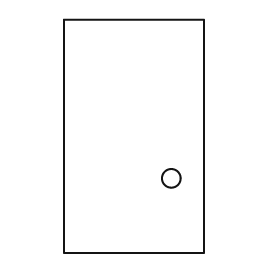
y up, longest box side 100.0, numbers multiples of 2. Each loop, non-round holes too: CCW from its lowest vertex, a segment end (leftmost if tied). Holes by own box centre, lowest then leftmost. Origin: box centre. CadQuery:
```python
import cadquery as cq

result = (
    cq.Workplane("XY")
    .moveTo(-30.0, -50.0)
    .lineTo(30.0, -50.0)
    .lineTo(30.0, 50.0)
    .lineTo(-30.0, 50.0)
    .close()
    .moveTo(16.0, -18.0)
    .circle(4.0)
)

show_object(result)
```